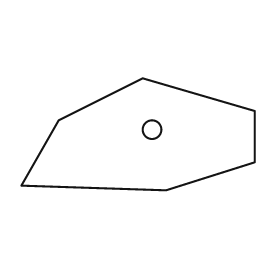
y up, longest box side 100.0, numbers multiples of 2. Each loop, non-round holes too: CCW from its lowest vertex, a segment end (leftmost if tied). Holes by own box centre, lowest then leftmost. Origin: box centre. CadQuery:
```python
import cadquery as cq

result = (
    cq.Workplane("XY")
    .moveTo(12.0, -24.0)
    .lineTo(50.0, -12.0)
    .lineTo(50.0, 10.0)
    .lineTo(2.0, 24.0)
    .lineTo(-34.0, 6.0)
    .lineTo(-50.0, -22.0)
    .close()
    .moveTo(6.0, 2.0)
    .circle(4.0)
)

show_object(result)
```